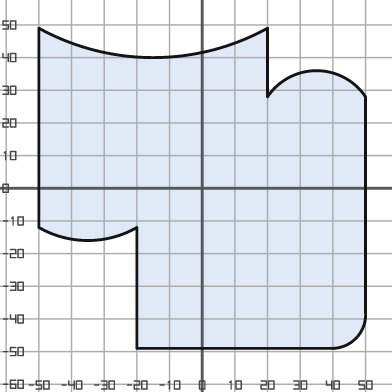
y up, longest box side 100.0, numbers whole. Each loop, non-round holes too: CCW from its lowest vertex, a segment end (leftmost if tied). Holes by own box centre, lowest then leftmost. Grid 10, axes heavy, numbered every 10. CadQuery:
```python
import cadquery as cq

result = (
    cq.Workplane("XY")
    .moveTo(-20.0, -49.0)
    .lineTo(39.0, -49.0)
    .threePointArc((47.0, -46.0), (50.0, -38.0))
    .lineTo(50.0, 28.0)
    .threePointArc((35.0, 36.0), (20.0, 28.0))
    .lineTo(20.0, 49.0)
    .threePointArc((-15.0, 40.0), (-50.0, 49.0))
    .lineTo(-50.0, -12.0)
    .threePointArc((-35.0, -16.0), (-20.0, -12.0))
    .close()
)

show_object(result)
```